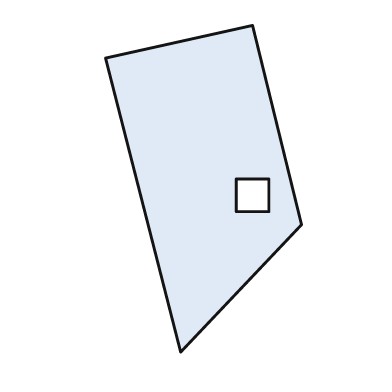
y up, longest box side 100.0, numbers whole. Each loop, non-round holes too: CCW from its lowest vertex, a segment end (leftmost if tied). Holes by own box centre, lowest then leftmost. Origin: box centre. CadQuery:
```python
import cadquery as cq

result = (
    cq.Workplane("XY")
    .moveTo(-7.0, -50.0)
    .lineTo(30.0, -11.0)
    .lineTo(15.0, 50.0)
    .lineTo(-30.0, 40.0)
    .close()
    .moveTo(10.0, -7.0)
    .lineTo(20.0, -7.0)
    .lineTo(20.0, 3.0)
    .lineTo(10.0, 3.0)
    .close()
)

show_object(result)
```